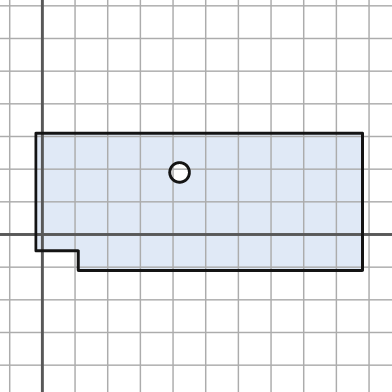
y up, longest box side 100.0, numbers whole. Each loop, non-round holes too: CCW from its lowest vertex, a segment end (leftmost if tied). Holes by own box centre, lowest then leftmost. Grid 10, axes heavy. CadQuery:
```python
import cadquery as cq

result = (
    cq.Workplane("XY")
    .moveTo(11.0, -11.0)
    .lineTo(98.0, -11.0)
    .lineTo(98.0, 31.0)
    .lineTo(-2.0, 31.0)
    .lineTo(-2.0, -5.0)
    .lineTo(11.0, -5.0)
    .close()
    .moveTo(42.0, 19.0)
    .circle(3.0)
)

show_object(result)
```